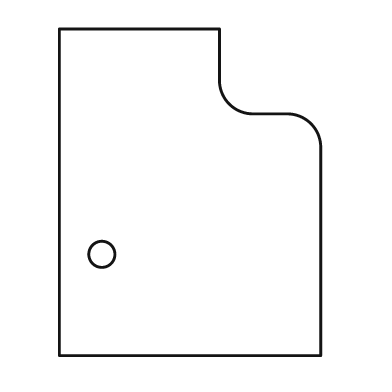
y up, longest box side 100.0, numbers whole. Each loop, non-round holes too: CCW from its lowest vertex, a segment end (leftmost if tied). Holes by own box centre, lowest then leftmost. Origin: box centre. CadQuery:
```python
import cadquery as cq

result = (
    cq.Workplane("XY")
    .moveTo(-40.0, -50.0)
    .lineTo(40.0, -50.0)
    .lineTo(40.0, 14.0)
    .threePointArc((37.0, 21.0), (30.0, 24.0))
    .lineTo(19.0, 24.0)
    .threePointArc((12.0, 27.0), (9.0, 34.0))
    .lineTo(9.0, 50.0)
    .lineTo(-40.0, 50.0)
    .close()
    .moveTo(-27.0, -19.0)
    .circle(4.0)
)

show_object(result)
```